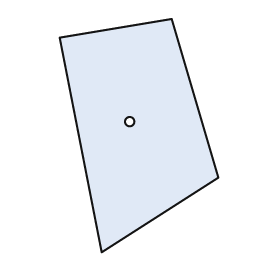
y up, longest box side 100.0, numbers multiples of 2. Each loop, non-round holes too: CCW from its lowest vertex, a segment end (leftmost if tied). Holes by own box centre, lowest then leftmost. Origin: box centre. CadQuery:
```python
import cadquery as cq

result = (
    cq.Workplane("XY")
    .moveTo(-16.0, -50.0)
    .lineTo(34.0, -18.0)
    .lineTo(14.0, 50.0)
    .lineTo(-34.0, 42.0)
    .close()
    .moveTo(-4.0, 6.0)
    .circle(2.0)
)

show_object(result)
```